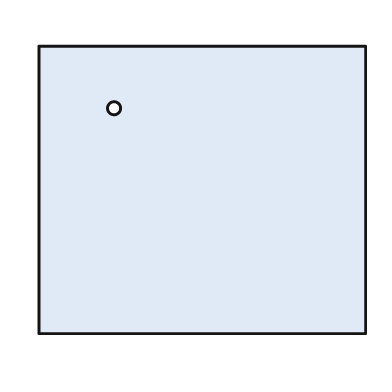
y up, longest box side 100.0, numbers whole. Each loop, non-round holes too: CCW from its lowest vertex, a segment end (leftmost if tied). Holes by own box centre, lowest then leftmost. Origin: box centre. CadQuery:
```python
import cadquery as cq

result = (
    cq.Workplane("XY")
    .moveTo(-50.0, -44.0)
    .lineTo(50.0, -44.0)
    .lineTo(50.0, 44.0)
    .lineTo(-50.0, 44.0)
    .close()
    .moveTo(-27.0, 25.0)
    .circle(2.0)
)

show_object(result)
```